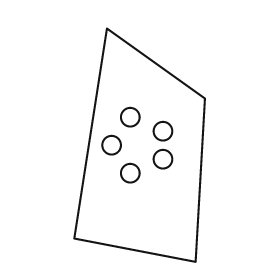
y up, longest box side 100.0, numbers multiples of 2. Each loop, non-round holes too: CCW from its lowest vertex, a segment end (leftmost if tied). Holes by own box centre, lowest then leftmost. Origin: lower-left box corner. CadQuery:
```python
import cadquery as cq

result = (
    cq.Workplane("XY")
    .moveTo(52.0, 0.0)
    .lineTo(56.0, 70.0)
    .lineTo(14.0, 100.0)
    .lineTo(0.0, 10.0)
    .close()
    .moveTo(24.0, 38.0)
    .circle(4.0)
    .moveTo(38.0, 44.0)
    .circle(4.0)
    .moveTo(16.0, 50.0)
    .circle(4.0)
    .moveTo(38.0, 56.0)
    .circle(4.0)
    .moveTo(24.0, 62.0)
    .circle(4.0)
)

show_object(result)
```